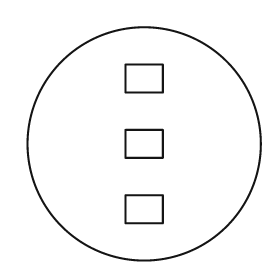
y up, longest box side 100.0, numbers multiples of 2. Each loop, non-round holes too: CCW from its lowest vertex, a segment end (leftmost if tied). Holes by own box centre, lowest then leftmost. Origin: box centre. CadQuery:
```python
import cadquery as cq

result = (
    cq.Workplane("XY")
    .moveTo(0.0, 0.0)
    .circle(50.0)
    .moveTo(-8.0, -34.0)
    .lineTo(8.0, -34.0)
    .lineTo(8.0, -22.0)
    .lineTo(-8.0, -22.0)
    .close()
    .moveTo(-8.0, -6.0)
    .lineTo(8.0, -6.0)
    .lineTo(8.0, 6.0)
    .lineTo(-8.0, 6.0)
    .close()
    .moveTo(-8.0, 22.0)
    .lineTo(8.0, 22.0)
    .lineTo(8.0, 34.0)
    .lineTo(-8.0, 34.0)
    .close()
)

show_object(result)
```